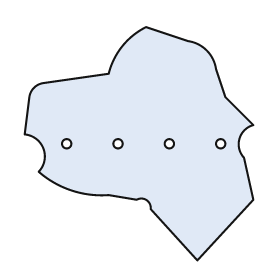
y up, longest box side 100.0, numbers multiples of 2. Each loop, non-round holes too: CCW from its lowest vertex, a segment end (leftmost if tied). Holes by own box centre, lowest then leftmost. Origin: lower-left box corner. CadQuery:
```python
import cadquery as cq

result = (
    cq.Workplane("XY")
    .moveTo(74.0, 0.0)
    .lineTo(98.0, 26.0)
    .lineTo(94.0, 44.0)
    .threePointArc((92.0, 52.0), (98.0, 58.0))
    .lineTo(86.0, 70.0)
    .lineTo(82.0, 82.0)
    .threePointArc((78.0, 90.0), (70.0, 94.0))
    .lineTo(52.0, 100.0)
    .threePointArc((42.0, 92.0), (36.0, 80.0))
    .lineTo(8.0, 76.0)
    .threePointArc((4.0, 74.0), (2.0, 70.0))
    .lineTo(0.0, 54.0)
    .threePointArc((8.0, 48.0), (6.0, 38.0))
    .threePointArc((20.0, 30.0), (36.0, 28.0))
    .lineTo(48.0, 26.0)
    .threePointArc((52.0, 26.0), (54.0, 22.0))
    .close()
    .moveTo(18.0, 50.0)
    .circle(2.0)
    .moveTo(40.0, 50.0)
    .circle(2.0)
    .moveTo(62.0, 50.0)
    .circle(2.0)
    .moveTo(84.0, 50.0)
    .circle(2.0)
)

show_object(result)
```